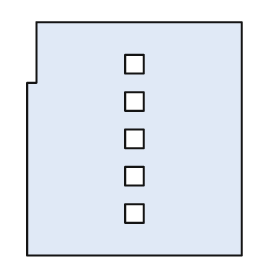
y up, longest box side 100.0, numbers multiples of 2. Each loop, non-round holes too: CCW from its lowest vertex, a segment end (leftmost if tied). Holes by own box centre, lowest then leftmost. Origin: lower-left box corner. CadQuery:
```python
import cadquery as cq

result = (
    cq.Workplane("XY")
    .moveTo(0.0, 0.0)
    .lineTo(92.0, 0.0)
    .lineTo(92.0, 100.0)
    .lineTo(4.0, 100.0)
    .lineTo(4.0, 74.0)
    .lineTo(0.0, 74.0)
    .close()
    .moveTo(42.0, 14.0)
    .lineTo(50.0, 14.0)
    .lineTo(50.0, 22.0)
    .lineTo(42.0, 22.0)
    .close()
    .moveTo(42.0, 30.0)
    .lineTo(50.0, 30.0)
    .lineTo(50.0, 38.0)
    .lineTo(42.0, 38.0)
    .close()
    .moveTo(42.0, 46.0)
    .lineTo(50.0, 46.0)
    .lineTo(50.0, 54.0)
    .lineTo(42.0, 54.0)
    .close()
    .moveTo(42.0, 62.0)
    .lineTo(50.0, 62.0)
    .lineTo(50.0, 70.0)
    .lineTo(42.0, 70.0)
    .close()
    .moveTo(42.0, 78.0)
    .lineTo(50.0, 78.0)
    .lineTo(50.0, 86.0)
    .lineTo(42.0, 86.0)
    .close()
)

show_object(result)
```